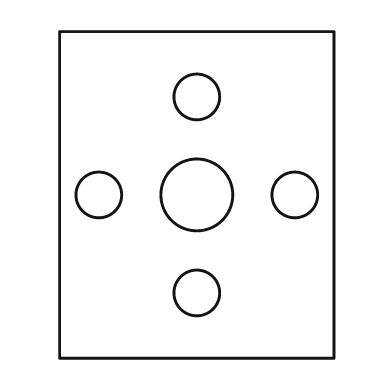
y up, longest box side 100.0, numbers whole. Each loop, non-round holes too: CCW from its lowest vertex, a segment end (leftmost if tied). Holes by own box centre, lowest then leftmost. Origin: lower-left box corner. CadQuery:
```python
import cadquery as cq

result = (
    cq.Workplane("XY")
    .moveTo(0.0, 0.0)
    .lineTo(84.0, 0.0)
    .lineTo(84.0, 100.0)
    .lineTo(0.0, 100.0)
    .close()
    .moveTo(42.0, 20.0)
    .circle(7.0)
    .moveTo(12.0, 50.0)
    .circle(7.0)
    .moveTo(42.0, 50.0)
    .circle(11.0)
    .moveTo(72.0, 50.0)
    .circle(7.0)
    .moveTo(42.0, 80.0)
    .circle(7.0)
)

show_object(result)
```